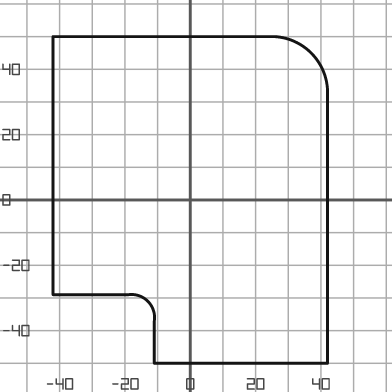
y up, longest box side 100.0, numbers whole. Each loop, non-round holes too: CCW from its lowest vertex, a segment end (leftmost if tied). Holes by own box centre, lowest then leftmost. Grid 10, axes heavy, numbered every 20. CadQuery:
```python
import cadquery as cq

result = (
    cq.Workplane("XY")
    .moveTo(-11.0, -50.0)
    .lineTo(42.0, -50.0)
    .lineTo(42.0, 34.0)
    .threePointArc((37.0, 45.0), (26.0, 50.0))
    .lineTo(-42.0, 50.0)
    .lineTo(-42.0, -29.0)
    .lineTo(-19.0, -29.0)
    .threePointArc((-13.0, -31.0), (-11.0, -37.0))
    .close()
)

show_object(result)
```